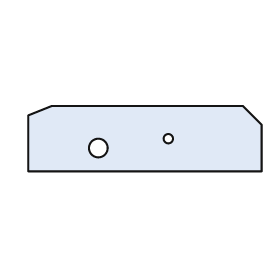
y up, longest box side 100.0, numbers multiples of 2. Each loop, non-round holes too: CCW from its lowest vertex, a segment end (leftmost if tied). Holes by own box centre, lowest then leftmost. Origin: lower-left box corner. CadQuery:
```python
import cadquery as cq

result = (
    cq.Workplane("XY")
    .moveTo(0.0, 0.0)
    .lineTo(100.0, 0.0)
    .lineTo(100.0, 20.0)
    .lineTo(92.0, 28.0)
    .lineTo(10.0, 28.0)
    .lineTo(0.0, 24.0)
    .close()
    .moveTo(30.0, 10.0)
    .circle(4.0)
    .moveTo(60.0, 14.0)
    .circle(2.0)
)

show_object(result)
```